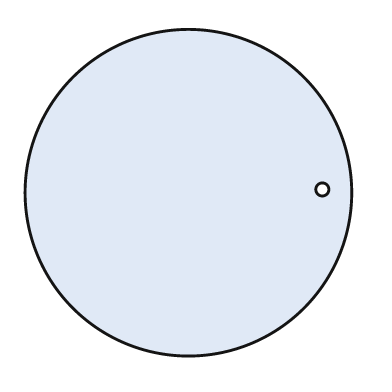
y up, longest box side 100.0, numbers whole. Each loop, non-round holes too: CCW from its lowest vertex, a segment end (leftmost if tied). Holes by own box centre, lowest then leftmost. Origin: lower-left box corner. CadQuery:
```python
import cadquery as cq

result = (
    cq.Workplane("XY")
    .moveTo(50.0, 50.0)
    .circle(50.0)
    .moveTo(91.0, 51.0)
    .circle(2.0)
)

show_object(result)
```